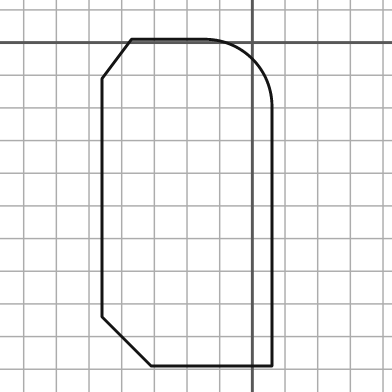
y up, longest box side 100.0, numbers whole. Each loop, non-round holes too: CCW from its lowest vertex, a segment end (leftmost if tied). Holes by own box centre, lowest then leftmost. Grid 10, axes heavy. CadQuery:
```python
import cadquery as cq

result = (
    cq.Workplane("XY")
    .moveTo(-31.0, -99.0)
    .lineTo(6.0, -99.0)
    .lineTo(6.0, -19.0)
    .threePointArc((0.0, -5.0), (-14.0, 1.0))
    .lineTo(-37.0, 1.0)
    .lineTo(-46.0, -11.0)
    .lineTo(-46.0, -84.0)
    .close()
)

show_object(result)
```